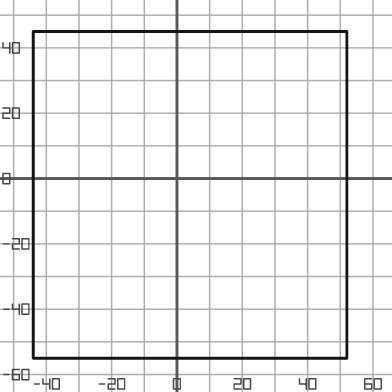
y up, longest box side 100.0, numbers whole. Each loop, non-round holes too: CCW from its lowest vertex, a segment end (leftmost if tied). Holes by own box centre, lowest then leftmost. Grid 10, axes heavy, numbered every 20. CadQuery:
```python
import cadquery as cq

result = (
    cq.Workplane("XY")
    .moveTo(-44.0, -55.0)
    .lineTo(52.0, -55.0)
    .lineTo(52.0, 45.0)
    .lineTo(-44.0, 45.0)
    .close()
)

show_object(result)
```